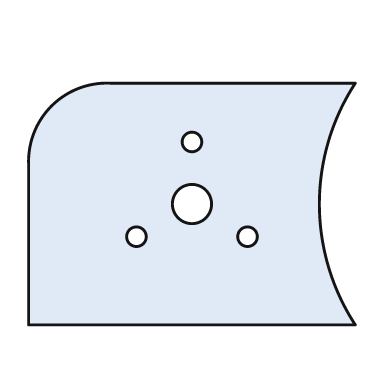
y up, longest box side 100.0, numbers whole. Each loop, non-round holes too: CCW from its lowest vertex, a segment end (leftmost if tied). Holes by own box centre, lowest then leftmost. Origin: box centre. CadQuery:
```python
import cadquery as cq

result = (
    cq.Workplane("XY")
    .moveTo(-50.0, -37.0)
    .lineTo(50.0, -37.0)
    .threePointArc((39.0, 0.0), (50.0, 37.0))
    .lineTo(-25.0, 37.0)
    .threePointArc((-43.0, 30.0), (-50.0, 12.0))
    .close()
    .moveTo(-17.0, -10.0)
    .circle(3.0)
    .moveTo(17.0, -10.0)
    .circle(3.0)
    .moveTo(0.0, 0.0)
    .circle(6.0)
    .moveTo(0.0, 19.0)
    .circle(3.0)
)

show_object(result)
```